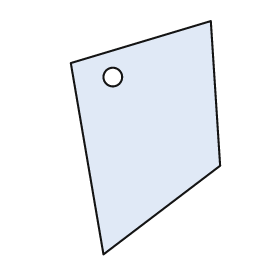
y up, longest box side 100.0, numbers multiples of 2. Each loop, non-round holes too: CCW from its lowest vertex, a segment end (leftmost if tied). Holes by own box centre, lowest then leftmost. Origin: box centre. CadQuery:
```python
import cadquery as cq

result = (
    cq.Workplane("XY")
    .moveTo(-18.0, -50.0)
    .lineTo(32.0, -12.0)
    .lineTo(28.0, 50.0)
    .lineTo(-32.0, 32.0)
    .close()
    .moveTo(-14.0, 26.0)
    .circle(4.0)
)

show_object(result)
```